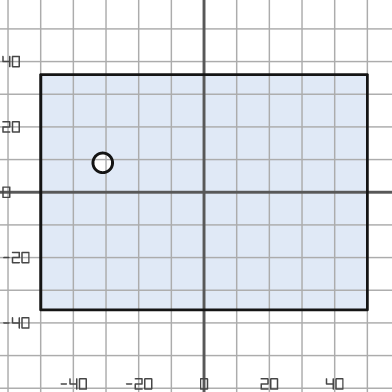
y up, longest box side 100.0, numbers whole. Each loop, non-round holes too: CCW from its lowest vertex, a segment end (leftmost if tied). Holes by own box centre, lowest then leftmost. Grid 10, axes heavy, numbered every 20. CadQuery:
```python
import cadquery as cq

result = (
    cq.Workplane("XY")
    .moveTo(-50.0, -36.0)
    .lineTo(50.0, -36.0)
    .lineTo(50.0, 36.0)
    .lineTo(-50.0, 36.0)
    .close()
    .moveTo(-31.0, 9.0)
    .circle(3.0)
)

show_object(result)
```